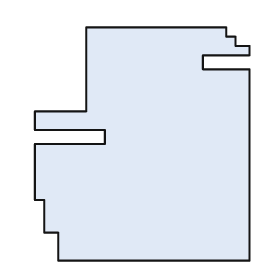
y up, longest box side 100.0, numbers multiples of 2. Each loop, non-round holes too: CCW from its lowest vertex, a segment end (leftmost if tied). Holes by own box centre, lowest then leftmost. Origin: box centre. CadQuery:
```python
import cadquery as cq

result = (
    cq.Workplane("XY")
    .moveTo(-36.0, -50.0)
    .lineTo(46.0, -50.0)
    .lineTo(46.0, 32.0)
    .lineTo(26.0, 32.0)
    .lineTo(26.0, 38.0)
    .lineTo(46.0, 38.0)
    .lineTo(46.0, 42.0)
    .lineTo(40.0, 42.0)
    .lineTo(40.0, 46.0)
    .lineTo(36.0, 46.0)
    .lineTo(36.0, 50.0)
    .lineTo(-24.0, 50.0)
    .lineTo(-24.0, 14.0)
    .lineTo(-46.0, 14.0)
    .lineTo(-46.0, 6.0)
    .lineTo(-16.0, 6.0)
    .lineTo(-16.0, 0.0)
    .lineTo(-46.0, 0.0)
    .lineTo(-46.0, -24.0)
    .lineTo(-42.0, -24.0)
    .lineTo(-42.0, -38.0)
    .lineTo(-36.0, -38.0)
    .close()
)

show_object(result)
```